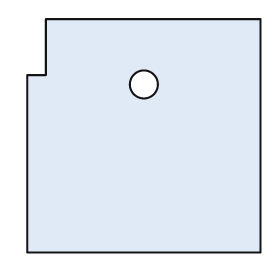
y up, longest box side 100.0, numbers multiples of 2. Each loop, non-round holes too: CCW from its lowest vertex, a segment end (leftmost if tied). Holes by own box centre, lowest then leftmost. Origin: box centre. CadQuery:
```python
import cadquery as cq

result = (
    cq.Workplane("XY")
    .moveTo(-50.0, -50.0)
    .lineTo(50.0, -50.0)
    .lineTo(50.0, 50.0)
    .lineTo(-42.0, 50.0)
    .lineTo(-42.0, 26.0)
    .lineTo(-50.0, 26.0)
    .close()
    .moveTo(0.0, 22.0)
    .circle(6.0)
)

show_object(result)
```